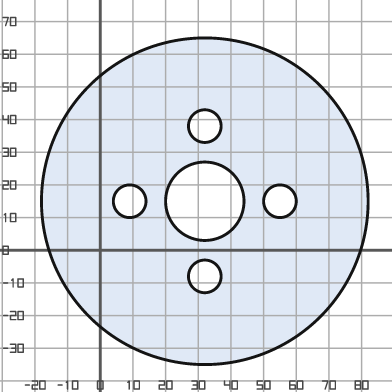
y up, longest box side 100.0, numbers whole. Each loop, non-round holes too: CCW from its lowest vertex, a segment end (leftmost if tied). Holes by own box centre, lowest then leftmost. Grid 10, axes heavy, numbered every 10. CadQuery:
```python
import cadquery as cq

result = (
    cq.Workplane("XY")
    .moveTo(32.0, 15.0)
    .circle(50.0)
    .moveTo(32.0, -8.0)
    .circle(5.0)
    .moveTo(9.0, 15.0)
    .circle(5.0)
    .moveTo(32.0, 15.0)
    .circle(12.0)
    .moveTo(55.0, 15.0)
    .circle(5.0)
    .moveTo(32.0, 38.0)
    .circle(5.0)
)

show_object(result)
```